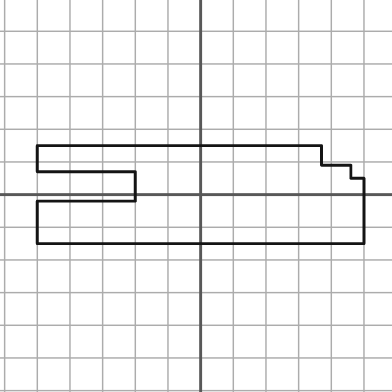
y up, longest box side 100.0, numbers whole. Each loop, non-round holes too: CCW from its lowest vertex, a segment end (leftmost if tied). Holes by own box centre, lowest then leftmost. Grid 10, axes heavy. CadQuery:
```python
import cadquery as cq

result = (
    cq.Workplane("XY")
    .moveTo(-50.0, -15.0)
    .lineTo(50.0, -15.0)
    .lineTo(50.0, 5.0)
    .lineTo(46.0, 5.0)
    .lineTo(46.0, 9.0)
    .lineTo(37.0, 9.0)
    .lineTo(37.0, 15.0)
    .lineTo(-50.0, 15.0)
    .lineTo(-50.0, 7.0)
    .lineTo(-20.0, 7.0)
    .lineTo(-20.0, -2.0)
    .lineTo(-50.0, -2.0)
    .close()
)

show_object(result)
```